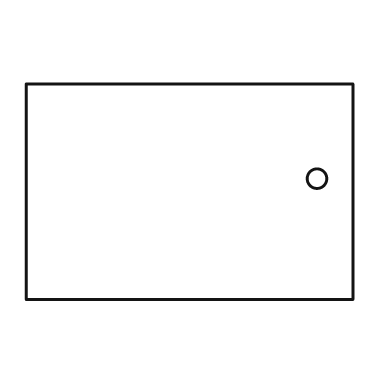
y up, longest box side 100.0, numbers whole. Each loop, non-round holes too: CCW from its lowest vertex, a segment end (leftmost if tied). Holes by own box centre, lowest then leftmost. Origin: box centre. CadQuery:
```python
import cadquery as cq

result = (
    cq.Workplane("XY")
    .moveTo(-50.0, -33.0)
    .lineTo(50.0, -33.0)
    .lineTo(50.0, 33.0)
    .lineTo(-50.0, 33.0)
    .close()
    .moveTo(39.0, 4.0)
    .circle(3.0)
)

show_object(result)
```